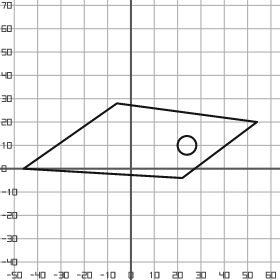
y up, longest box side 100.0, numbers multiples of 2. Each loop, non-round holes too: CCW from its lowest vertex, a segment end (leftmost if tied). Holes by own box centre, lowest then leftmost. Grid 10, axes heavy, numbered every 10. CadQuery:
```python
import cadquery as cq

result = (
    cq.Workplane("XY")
    .moveTo(22.0, -4.0)
    .lineTo(54.0, 20.0)
    .lineTo(-6.0, 28.0)
    .lineTo(-46.0, 0.0)
    .close()
    .moveTo(24.0, 10.0)
    .circle(4.0)
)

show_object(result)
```